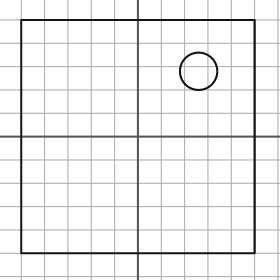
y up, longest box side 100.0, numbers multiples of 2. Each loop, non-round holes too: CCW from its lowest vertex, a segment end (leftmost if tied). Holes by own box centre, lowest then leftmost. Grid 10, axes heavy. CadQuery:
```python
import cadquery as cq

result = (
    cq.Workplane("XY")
    .moveTo(-50.0, -50.0)
    .lineTo(50.0, -50.0)
    .lineTo(50.0, 50.0)
    .lineTo(-50.0, 50.0)
    .close()
    .moveTo(26.0, 28.0)
    .circle(8.0)
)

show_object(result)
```